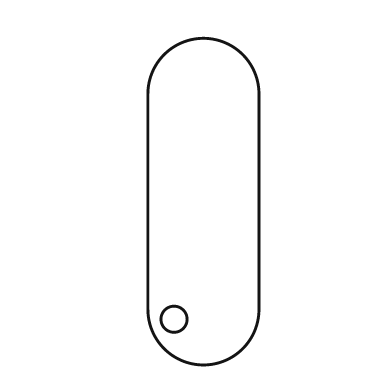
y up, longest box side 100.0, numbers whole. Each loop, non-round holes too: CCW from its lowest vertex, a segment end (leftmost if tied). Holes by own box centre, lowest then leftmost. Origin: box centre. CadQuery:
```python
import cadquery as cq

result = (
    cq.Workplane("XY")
    .moveTo(-17.0, -33.0)
    .threePointArc((0.0, -50.0), (17.0, -33.0))
    .lineTo(17.0, 33.0)
    .threePointArc((0.0, 50.0), (-17.0, 33.0))
    .close()
    .moveTo(-9.0, -36.0)
    .circle(4.0)
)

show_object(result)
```